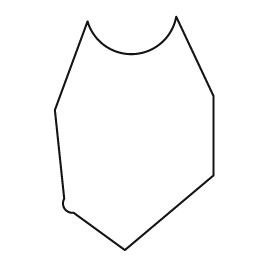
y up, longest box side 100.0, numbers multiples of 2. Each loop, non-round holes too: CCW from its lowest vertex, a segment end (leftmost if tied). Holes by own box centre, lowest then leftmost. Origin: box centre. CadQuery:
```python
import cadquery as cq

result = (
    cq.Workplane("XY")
    .moveTo(-4.0, -50.0)
    .lineTo(34.0, -18.0)
    .lineTo(34.0, 16.0)
    .lineTo(18.0, 50.0)
    .threePointArc((0.0, 34.0), (-20.0, 48.0))
    .lineTo(-34.0, 10.0)
    .lineTo(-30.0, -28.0)
    .threePointArc((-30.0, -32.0), (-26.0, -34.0))
    .close()
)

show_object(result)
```